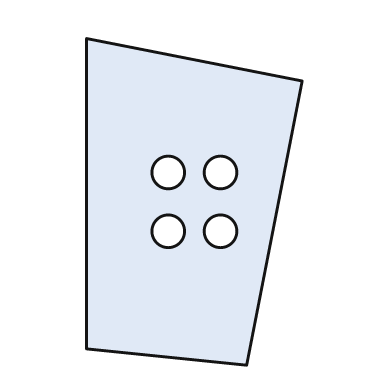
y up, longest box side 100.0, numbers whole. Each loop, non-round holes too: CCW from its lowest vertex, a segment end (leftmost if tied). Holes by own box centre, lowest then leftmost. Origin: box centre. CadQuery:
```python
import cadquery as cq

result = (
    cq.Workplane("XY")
    .moveTo(16.0, -50.0)
    .lineTo(33.0, 37.0)
    .lineTo(-33.0, 50.0)
    .lineTo(-33.0, -45.0)
    .close()
    .moveTo(-8.0, -9.0)
    .circle(5.0)
    .moveTo(8.0, -9.0)
    .circle(5.0)
    .moveTo(-8.0, 9.0)
    .circle(5.0)
    .moveTo(8.0, 9.0)
    .circle(5.0)
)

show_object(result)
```